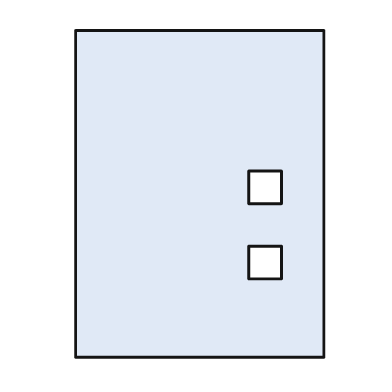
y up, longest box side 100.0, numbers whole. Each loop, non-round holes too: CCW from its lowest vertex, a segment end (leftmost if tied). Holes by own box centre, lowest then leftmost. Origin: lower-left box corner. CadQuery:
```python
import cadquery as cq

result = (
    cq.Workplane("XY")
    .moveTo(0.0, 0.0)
    .lineTo(76.0, 0.0)
    .lineTo(76.0, 100.0)
    .lineTo(0.0, 100.0)
    .close()
    .moveTo(53.0, 24.0)
    .lineTo(63.0, 24.0)
    .lineTo(63.0, 34.0)
    .lineTo(53.0, 34.0)
    .close()
    .moveTo(53.0, 47.0)
    .lineTo(63.0, 47.0)
    .lineTo(63.0, 57.0)
    .lineTo(53.0, 57.0)
    .close()
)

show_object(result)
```